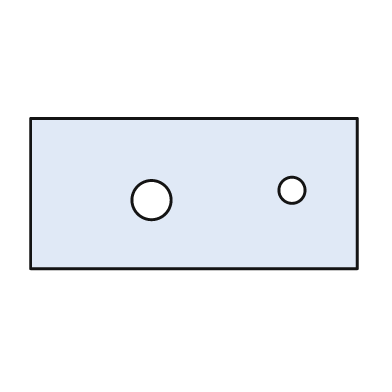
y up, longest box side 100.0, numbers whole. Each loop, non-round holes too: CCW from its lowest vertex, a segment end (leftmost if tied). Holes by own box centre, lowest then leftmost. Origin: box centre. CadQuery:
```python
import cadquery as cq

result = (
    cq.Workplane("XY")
    .moveTo(-50.0, -23.0)
    .lineTo(50.0, -23.0)
    .lineTo(50.0, 23.0)
    .lineTo(-50.0, 23.0)
    .close()
    .moveTo(-13.0, -2.0)
    .circle(6.0)
    .moveTo(30.0, 1.0)
    .circle(4.0)
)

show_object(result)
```